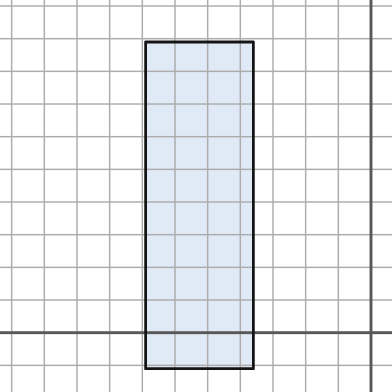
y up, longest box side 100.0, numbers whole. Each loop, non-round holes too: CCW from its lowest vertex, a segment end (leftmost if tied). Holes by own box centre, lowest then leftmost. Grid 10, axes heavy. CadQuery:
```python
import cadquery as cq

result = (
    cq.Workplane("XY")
    .moveTo(-69.0, -11.0)
    .lineTo(-36.0, -11.0)
    .lineTo(-36.0, 89.0)
    .lineTo(-69.0, 89.0)
    .close()
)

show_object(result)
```